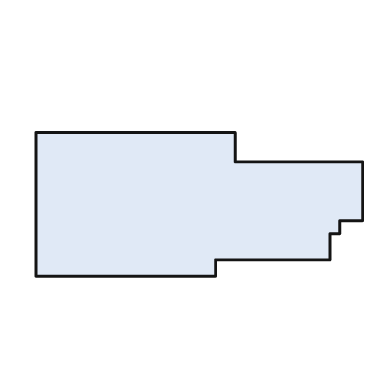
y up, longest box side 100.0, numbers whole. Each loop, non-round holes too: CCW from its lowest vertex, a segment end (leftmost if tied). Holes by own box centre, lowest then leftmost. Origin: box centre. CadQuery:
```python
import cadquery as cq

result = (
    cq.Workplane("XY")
    .moveTo(-50.0, -22.0)
    .lineTo(5.0, -22.0)
    .lineTo(5.0, -17.0)
    .lineTo(40.0, -17.0)
    .lineTo(40.0, -9.0)
    .lineTo(43.0, -9.0)
    .lineTo(43.0, -5.0)
    .lineTo(50.0, -5.0)
    .lineTo(50.0, 13.0)
    .lineTo(11.0, 13.0)
    .lineTo(11.0, 22.0)
    .lineTo(-50.0, 22.0)
    .close()
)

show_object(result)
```